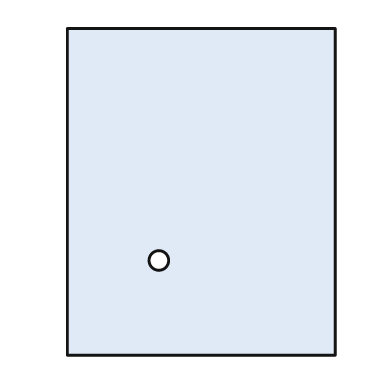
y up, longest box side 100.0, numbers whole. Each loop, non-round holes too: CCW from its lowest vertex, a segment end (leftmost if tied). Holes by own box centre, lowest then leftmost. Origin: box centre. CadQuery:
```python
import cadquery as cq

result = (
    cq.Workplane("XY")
    .moveTo(-41.0, -50.0)
    .lineTo(41.0, -50.0)
    .lineTo(41.0, 50.0)
    .lineTo(-41.0, 50.0)
    .close()
    .moveTo(-13.0, -21.0)
    .circle(3.0)
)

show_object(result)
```